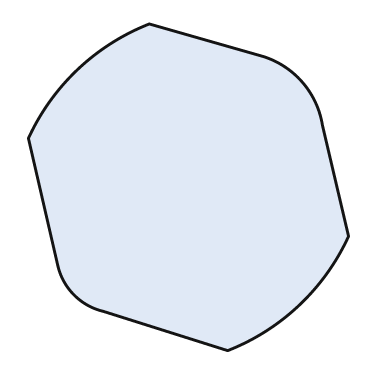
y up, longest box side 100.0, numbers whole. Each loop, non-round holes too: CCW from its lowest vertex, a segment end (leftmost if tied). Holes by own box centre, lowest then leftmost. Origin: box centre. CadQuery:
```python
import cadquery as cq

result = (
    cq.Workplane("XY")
    .moveTo(12.0, -50.0)
    .threePointArc((34.0, -36.0), (49.0, -15.0))
    .lineTo(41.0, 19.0)
    .threePointArc((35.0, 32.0), (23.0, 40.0))
    .lineTo(-12.0, 50.0)
    .threePointArc((-34.0, 36.0), (-49.0, 15.0))
    .lineTo(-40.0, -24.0)
    .threePointArc((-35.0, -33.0), (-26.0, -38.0))
    .close()
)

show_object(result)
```